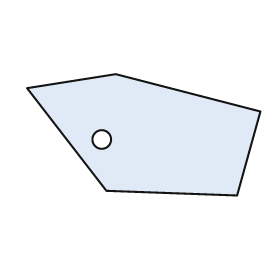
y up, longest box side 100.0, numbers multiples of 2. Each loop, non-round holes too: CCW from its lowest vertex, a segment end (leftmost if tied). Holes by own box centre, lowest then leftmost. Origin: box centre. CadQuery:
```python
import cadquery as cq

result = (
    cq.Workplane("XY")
    .moveTo(40.0, -26.0)
    .lineTo(50.0, 10.0)
    .lineTo(-12.0, 26.0)
    .lineTo(-50.0, 20.0)
    .lineTo(-16.0, -24.0)
    .close()
    .moveTo(-18.0, -2.0)
    .circle(4.0)
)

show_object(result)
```